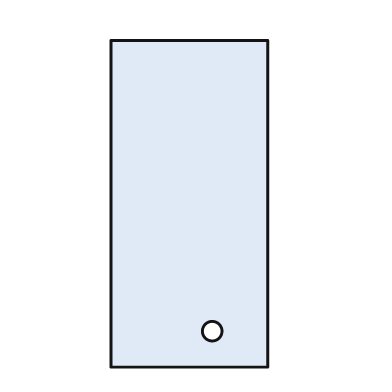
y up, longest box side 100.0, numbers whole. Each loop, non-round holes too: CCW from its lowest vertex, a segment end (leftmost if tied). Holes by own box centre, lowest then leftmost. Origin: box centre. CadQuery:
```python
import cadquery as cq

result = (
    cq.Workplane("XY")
    .moveTo(-24.0, -50.0)
    .lineTo(24.0, -50.0)
    .lineTo(24.0, 50.0)
    .lineTo(-24.0, 50.0)
    .close()
    .moveTo(7.0, -39.0)
    .circle(3.0)
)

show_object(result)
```